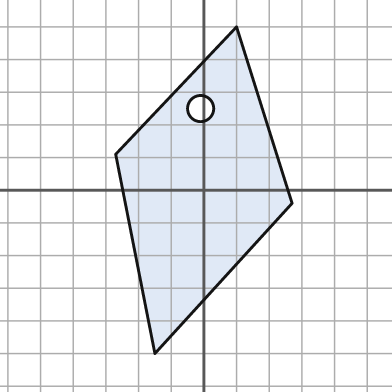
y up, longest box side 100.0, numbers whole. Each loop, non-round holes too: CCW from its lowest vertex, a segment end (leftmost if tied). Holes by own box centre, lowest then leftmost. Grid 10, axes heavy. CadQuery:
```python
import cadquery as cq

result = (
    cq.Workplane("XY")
    .moveTo(-15.0, -50.0)
    .lineTo(27.0, -4.0)
    .lineTo(10.0, 50.0)
    .lineTo(-27.0, 11.0)
    .close()
    .moveTo(-1.0, 25.0)
    .circle(4.0)
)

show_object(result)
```